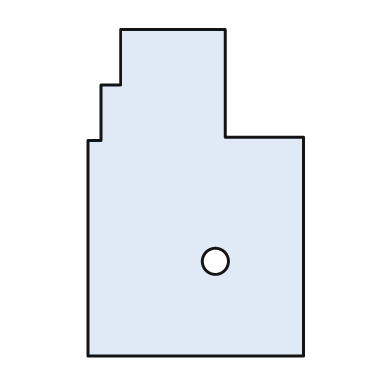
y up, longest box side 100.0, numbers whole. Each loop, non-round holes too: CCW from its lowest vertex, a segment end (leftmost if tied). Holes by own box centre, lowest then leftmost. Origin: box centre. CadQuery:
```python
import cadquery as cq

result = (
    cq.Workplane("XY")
    .moveTo(-33.0, -50.0)
    .lineTo(33.0, -50.0)
    .lineTo(33.0, 17.0)
    .lineTo(9.0, 17.0)
    .lineTo(9.0, 50.0)
    .lineTo(-23.0, 50.0)
    .lineTo(-23.0, 33.0)
    .lineTo(-29.0, 33.0)
    .lineTo(-29.0, 16.0)
    .lineTo(-33.0, 16.0)
    .close()
    .moveTo(6.0, -21.0)
    .circle(4.0)
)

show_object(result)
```